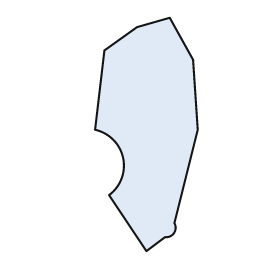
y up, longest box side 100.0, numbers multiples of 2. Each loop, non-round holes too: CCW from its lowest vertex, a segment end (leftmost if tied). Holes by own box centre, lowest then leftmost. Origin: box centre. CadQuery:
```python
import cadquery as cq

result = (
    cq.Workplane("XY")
    .moveTo(0.0, -50.0)
    .lineTo(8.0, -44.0)
    .threePointArc((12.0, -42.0), (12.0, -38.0))
    .lineTo(22.0, 2.0)
    .lineTo(20.0, 32.0)
    .lineTo(10.0, 50.0)
    .lineTo(-4.0, 46.0)
    .lineTo(-18.0, 36.0)
    .lineTo(-22.0, 2.0)
    .threePointArc((-10.0, -10.0), (-16.0, -26.0))
    .close()
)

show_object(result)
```